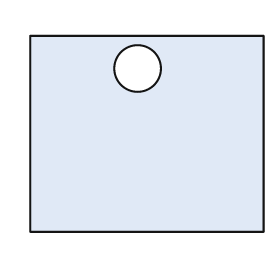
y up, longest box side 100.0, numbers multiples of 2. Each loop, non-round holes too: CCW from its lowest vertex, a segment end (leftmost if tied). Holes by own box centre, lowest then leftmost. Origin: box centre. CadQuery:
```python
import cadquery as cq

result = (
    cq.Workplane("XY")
    .moveTo(-50.0, -42.0)
    .lineTo(50.0, -42.0)
    .lineTo(50.0, 42.0)
    .lineTo(-50.0, 42.0)
    .close()
    .moveTo(-4.0, 28.0)
    .circle(10.0)
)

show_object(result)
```